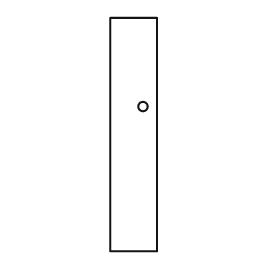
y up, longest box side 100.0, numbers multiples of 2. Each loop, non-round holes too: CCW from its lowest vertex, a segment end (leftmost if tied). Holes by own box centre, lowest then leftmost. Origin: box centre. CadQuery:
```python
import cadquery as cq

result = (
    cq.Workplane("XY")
    .moveTo(-10.0, -50.0)
    .lineTo(10.0, -50.0)
    .lineTo(10.0, 50.0)
    .lineTo(-10.0, 50.0)
    .close()
    .moveTo(4.0, 12.0)
    .circle(2.0)
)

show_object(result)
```